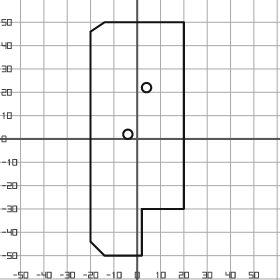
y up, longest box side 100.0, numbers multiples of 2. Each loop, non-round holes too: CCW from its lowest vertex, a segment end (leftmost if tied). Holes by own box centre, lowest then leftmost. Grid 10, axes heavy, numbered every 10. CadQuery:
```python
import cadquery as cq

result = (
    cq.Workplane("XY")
    .moveTo(-14.0, -50.0)
    .lineTo(2.0, -50.0)
    .lineTo(2.0, -30.0)
    .lineTo(20.0, -30.0)
    .lineTo(20.0, 50.0)
    .lineTo(-14.0, 50.0)
    .lineTo(-20.0, 46.0)
    .lineTo(-20.0, -44.0)
    .close()
    .moveTo(-4.0, 2.0)
    .circle(2.0)
    .moveTo(4.0, 22.0)
    .circle(2.0)
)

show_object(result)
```